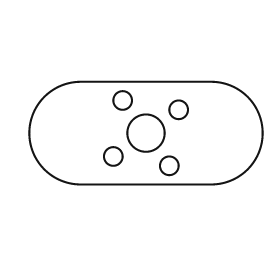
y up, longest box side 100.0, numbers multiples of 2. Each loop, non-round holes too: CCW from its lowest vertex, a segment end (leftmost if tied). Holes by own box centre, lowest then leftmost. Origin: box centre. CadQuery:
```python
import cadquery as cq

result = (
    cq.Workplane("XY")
    .moveTo(-28.0, -22.0)
    .lineTo(28.0, -22.0)
    .threePointArc((50.0, 0.0), (28.0, 22.0))
    .lineTo(-28.0, 22.0)
    .threePointArc((-50.0, 0.0), (-28.0, -22.0))
    .close()
    .moveTo(10.0, -14.0)
    .circle(4.0)
    .moveTo(-14.0, -10.0)
    .circle(4.0)
    .moveTo(0.0, 0.0)
    .circle(8.0)
    .moveTo(14.0, 10.0)
    .circle(4.0)
    .moveTo(-10.0, 14.0)
    .circle(4.0)
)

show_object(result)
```